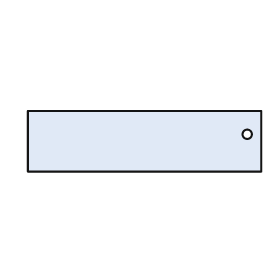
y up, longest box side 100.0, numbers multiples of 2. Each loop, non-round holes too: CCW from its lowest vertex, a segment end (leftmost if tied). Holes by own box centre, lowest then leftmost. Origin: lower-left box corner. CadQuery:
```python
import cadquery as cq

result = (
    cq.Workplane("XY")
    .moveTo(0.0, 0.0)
    .lineTo(100.0, 0.0)
    .lineTo(100.0, 26.0)
    .lineTo(0.0, 26.0)
    .close()
    .moveTo(94.0, 16.0)
    .circle(2.0)
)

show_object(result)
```